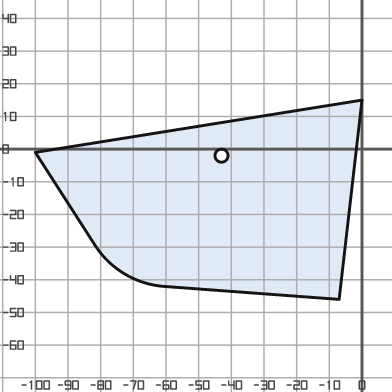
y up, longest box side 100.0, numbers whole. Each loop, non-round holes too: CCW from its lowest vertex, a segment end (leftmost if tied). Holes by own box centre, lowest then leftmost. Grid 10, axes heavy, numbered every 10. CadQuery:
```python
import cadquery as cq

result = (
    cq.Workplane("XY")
    .moveTo(-7.0, -46.0)
    .lineTo(0.0, 15.0)
    .lineTo(-100.0, -1.0)
    .lineTo(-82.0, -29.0)
    .threePointArc((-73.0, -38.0), (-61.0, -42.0))
    .close()
    .moveTo(-43.0, -2.0)
    .circle(2.0)
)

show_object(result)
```